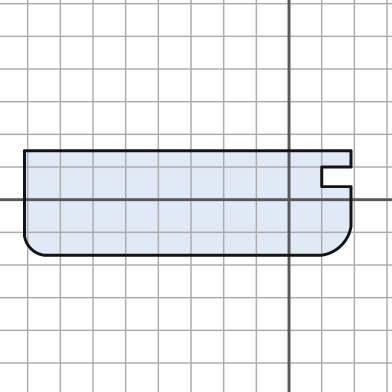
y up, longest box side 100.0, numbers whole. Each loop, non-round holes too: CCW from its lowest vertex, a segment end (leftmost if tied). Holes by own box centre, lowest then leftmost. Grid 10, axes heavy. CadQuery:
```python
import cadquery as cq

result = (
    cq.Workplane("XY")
    .moveTo(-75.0, -17.0)
    .lineTo(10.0, -17.0)
    .threePointArc((16.0, -14.0), (19.0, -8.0))
    .lineTo(19.0, 4.0)
    .lineTo(10.0, 4.0)
    .lineTo(10.0, 10.0)
    .lineTo(19.0, 10.0)
    .lineTo(19.0, 15.0)
    .lineTo(-81.0, 15.0)
    .lineTo(-81.0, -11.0)
    .threePointArc((-79.0, -15.0), (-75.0, -17.0))
    .close()
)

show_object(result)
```